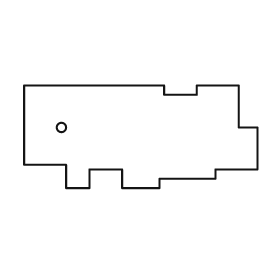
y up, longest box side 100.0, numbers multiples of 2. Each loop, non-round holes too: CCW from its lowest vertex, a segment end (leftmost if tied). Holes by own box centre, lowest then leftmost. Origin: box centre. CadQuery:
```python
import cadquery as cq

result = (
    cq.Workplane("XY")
    .moveTo(-32.0, -22.0)
    .lineTo(-22.0, -22.0)
    .lineTo(-22.0, -14.0)
    .lineTo(-8.0, -14.0)
    .lineTo(-8.0, -22.0)
    .lineTo(8.0, -22.0)
    .lineTo(8.0, -18.0)
    .lineTo(32.0, -18.0)
    .lineTo(32.0, -14.0)
    .lineTo(50.0, -14.0)
    .lineTo(50.0, 4.0)
    .lineTo(42.0, 4.0)
    .lineTo(42.0, 22.0)
    .lineTo(24.0, 22.0)
    .lineTo(24.0, 18.0)
    .lineTo(10.0, 18.0)
    .lineTo(10.0, 22.0)
    .lineTo(-50.0, 22.0)
    .lineTo(-50.0, -12.0)
    .lineTo(-32.0, -12.0)
    .close()
    .moveTo(-34.0, 4.0)
    .circle(2.0)
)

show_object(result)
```